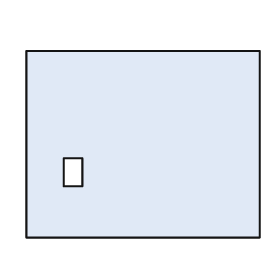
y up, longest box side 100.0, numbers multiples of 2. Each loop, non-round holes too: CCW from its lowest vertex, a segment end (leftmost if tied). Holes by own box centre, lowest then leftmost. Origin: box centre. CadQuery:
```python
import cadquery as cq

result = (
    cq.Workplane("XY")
    .moveTo(-50.0, -40.0)
    .lineTo(50.0, -40.0)
    .lineTo(50.0, 40.0)
    .lineTo(-50.0, 40.0)
    .close()
    .moveTo(-34.0, -18.0)
    .lineTo(-26.0, -18.0)
    .lineTo(-26.0, -6.0)
    .lineTo(-34.0, -6.0)
    .close()
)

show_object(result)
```